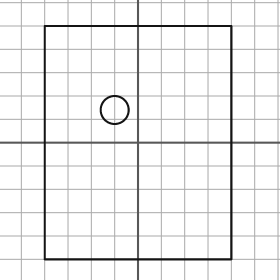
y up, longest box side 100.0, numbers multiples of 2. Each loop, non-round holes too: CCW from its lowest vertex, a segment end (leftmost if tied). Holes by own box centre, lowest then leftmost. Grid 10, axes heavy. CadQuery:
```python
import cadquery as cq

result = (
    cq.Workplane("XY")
    .moveTo(-40.0, -50.0)
    .lineTo(40.0, -50.0)
    .lineTo(40.0, 50.0)
    .lineTo(-40.0, 50.0)
    .close()
    .moveTo(-10.0, 14.0)
    .circle(6.0)
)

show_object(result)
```